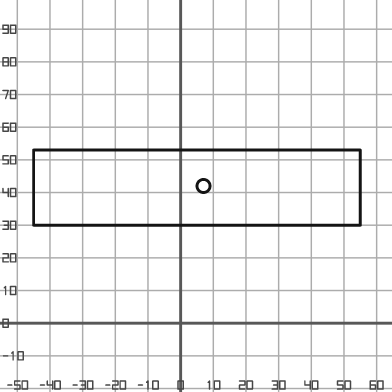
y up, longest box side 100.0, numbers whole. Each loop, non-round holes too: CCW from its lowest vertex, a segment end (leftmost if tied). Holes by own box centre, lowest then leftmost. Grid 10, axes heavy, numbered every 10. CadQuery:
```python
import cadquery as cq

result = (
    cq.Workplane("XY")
    .moveTo(-45.0, 30.0)
    .lineTo(55.0, 30.0)
    .lineTo(55.0, 53.0)
    .lineTo(-45.0, 53.0)
    .close()
    .moveTo(7.0, 42.0)
    .circle(2.0)
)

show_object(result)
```